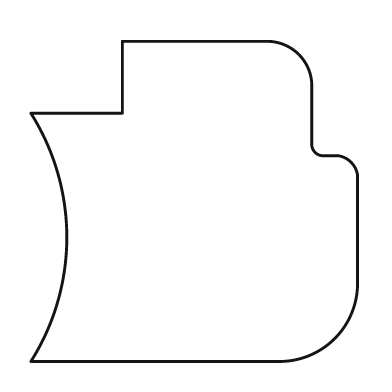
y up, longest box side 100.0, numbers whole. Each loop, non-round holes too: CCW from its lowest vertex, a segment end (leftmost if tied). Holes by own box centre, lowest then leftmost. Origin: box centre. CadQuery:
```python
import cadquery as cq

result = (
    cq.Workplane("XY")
    .moveTo(-50.0, -49.0)
    .lineTo(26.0, -49.0)
    .threePointArc((43.0, -42.0), (50.0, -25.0))
    .lineTo(50.0, 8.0)
    .threePointArc((48.0, 12.0), (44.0, 14.0))
    .lineTo(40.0, 14.0)
    .threePointArc((37.0, 15.0), (36.0, 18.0))
    .lineTo(36.0, 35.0)
    .threePointArc((32.0, 45.0), (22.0, 49.0))
    .lineTo(-22.0, 49.0)
    .lineTo(-22.0, 27.0)
    .lineTo(-50.0, 27.0)
    .threePointArc((-39.0, -11.0), (-50.0, -49.0))
    .close()
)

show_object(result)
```